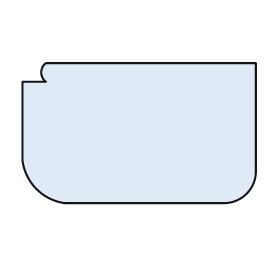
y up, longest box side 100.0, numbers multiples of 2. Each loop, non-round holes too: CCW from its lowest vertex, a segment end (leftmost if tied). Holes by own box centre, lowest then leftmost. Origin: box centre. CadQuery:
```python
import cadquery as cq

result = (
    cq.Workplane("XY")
    .moveTo(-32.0, -30.0)
    .lineTo(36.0, -30.0)
    .threePointArc((46.0, -26.0), (50.0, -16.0))
    .lineTo(50.0, 30.0)
    .lineTo(-40.0, 30.0)
    .threePointArc((-42.0, 26.0), (-40.0, 22.0))
    .lineTo(-50.0, 22.0)
    .lineTo(-50.0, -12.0)
    .threePointArc((-44.0, -24.0), (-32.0, -30.0))
    .close()
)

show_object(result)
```